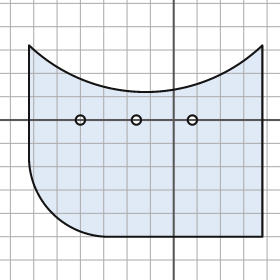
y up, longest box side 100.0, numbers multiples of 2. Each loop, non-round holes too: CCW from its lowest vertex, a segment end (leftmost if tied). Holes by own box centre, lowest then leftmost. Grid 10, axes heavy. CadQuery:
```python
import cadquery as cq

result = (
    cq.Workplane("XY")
    .moveTo(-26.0, -50.0)
    .lineTo(38.0, -50.0)
    .lineTo(38.0, 32.0)
    .threePointArc((-12.0, 12.0), (-62.0, 32.0))
    .lineTo(-62.0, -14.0)
    .threePointArc((-52.0, -40.0), (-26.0, -50.0))
    .close()
    .moveTo(-40.0, 0.0)
    .circle(2.0)
    .moveTo(-16.0, 0.0)
    .circle(2.0)
    .moveTo(8.0, 0.0)
    .circle(2.0)
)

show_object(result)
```